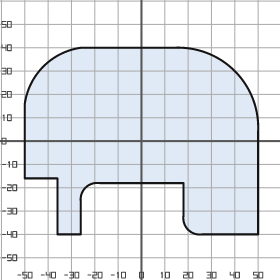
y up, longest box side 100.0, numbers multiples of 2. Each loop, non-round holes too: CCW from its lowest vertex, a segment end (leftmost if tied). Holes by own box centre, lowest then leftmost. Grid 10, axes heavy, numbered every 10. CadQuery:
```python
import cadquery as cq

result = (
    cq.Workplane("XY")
    .moveTo(-36.0, -40.0)
    .lineTo(-26.0, -40.0)
    .lineTo(-26.0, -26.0)
    .threePointArc((-24.0, -20.0), (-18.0, -18.0))
    .lineTo(18.0, -18.0)
    .lineTo(18.0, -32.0)
    .threePointArc((20.0, -38.0), (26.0, -40.0))
    .lineTo(50.0, -40.0)
    .lineTo(50.0, 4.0)
    .threePointArc((40.0, 30.0), (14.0, 40.0))
    .lineTo(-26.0, 40.0)
    .threePointArc((-42.0, 32.0), (-50.0, 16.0))
    .lineTo(-50.0, -16.0)
    .lineTo(-36.0, -16.0)
    .close()
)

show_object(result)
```